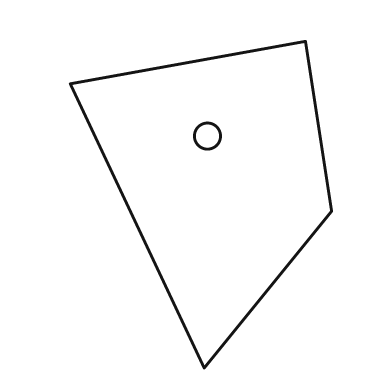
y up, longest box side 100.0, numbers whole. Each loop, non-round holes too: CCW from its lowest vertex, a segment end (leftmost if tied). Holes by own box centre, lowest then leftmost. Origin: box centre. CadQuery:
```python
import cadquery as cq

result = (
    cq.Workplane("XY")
    .moveTo(1.0, -50.0)
    .lineTo(40.0, -2.0)
    .lineTo(32.0, 50.0)
    .lineTo(-40.0, 37.0)
    .close()
    .moveTo(2.0, 21.0)
    .circle(4.0)
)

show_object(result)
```